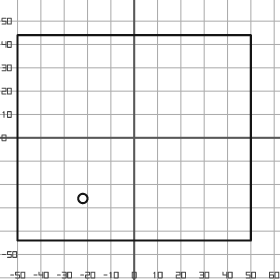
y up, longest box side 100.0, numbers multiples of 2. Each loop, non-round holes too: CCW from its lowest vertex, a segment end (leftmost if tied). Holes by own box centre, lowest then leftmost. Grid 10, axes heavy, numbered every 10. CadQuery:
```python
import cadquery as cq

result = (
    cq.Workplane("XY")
    .moveTo(-50.0, -44.0)
    .lineTo(50.0, -44.0)
    .lineTo(50.0, 44.0)
    .lineTo(-50.0, 44.0)
    .close()
    .moveTo(-22.0, -26.0)
    .circle(2.0)
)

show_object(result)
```